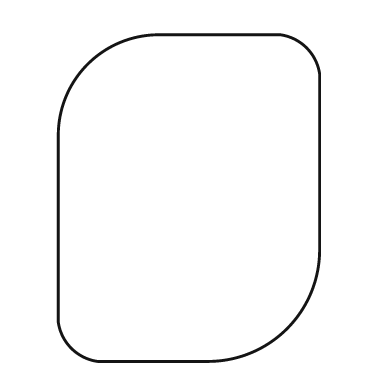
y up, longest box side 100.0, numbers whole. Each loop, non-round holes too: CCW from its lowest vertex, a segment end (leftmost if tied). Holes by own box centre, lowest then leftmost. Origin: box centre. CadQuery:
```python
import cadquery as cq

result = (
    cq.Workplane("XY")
    .moveTo(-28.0, -50.0)
    .lineTo(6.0, -50.0)
    .threePointArc((30.0, -40.0), (40.0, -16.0))
    .lineTo(40.0, 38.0)
    .threePointArc((36.0, 46.0), (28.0, 50.0))
    .lineTo(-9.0, 50.0)
    .threePointArc((-31.0, 41.0), (-40.0, 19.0))
    .lineTo(-40.0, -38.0)
    .threePointArc((-36.0, -46.0), (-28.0, -50.0))
    .close()
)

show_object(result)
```